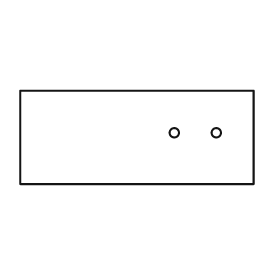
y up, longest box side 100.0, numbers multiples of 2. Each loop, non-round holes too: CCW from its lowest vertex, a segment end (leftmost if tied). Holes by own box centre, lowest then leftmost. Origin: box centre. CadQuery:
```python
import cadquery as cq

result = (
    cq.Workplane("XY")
    .moveTo(-50.0, -20.0)
    .lineTo(50.0, -20.0)
    .lineTo(50.0, 20.0)
    .lineTo(-50.0, 20.0)
    .close()
    .moveTo(16.0, 2.0)
    .circle(2.0)
    .moveTo(34.0, 2.0)
    .circle(2.0)
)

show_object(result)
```